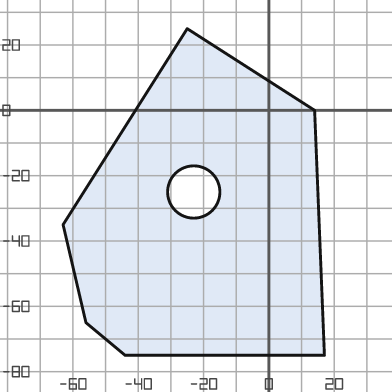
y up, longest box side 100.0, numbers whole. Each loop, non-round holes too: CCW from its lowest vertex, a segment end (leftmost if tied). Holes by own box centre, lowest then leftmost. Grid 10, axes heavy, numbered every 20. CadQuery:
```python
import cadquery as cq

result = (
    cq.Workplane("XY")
    .moveTo(-44.0, -75.0)
    .lineTo(17.0, -75.0)
    .lineTo(14.0, 0.0)
    .lineTo(-25.0, 25.0)
    .lineTo(-63.0, -35.0)
    .lineTo(-56.0, -65.0)
    .close()
    .moveTo(-23.0, -25.0)
    .circle(8.0)
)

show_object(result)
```